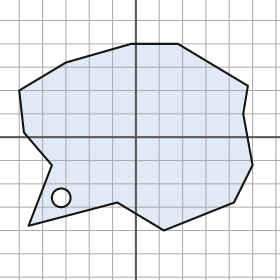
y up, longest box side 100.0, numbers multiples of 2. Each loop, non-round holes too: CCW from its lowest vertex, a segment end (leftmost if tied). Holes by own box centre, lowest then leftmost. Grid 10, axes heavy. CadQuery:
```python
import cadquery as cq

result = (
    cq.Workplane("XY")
    .moveTo(12.0, -40.0)
    .lineTo(42.0, -28.0)
    .lineTo(50.0, -12.0)
    .lineTo(46.0, 10.0)
    .lineTo(48.0, 22.0)
    .lineTo(18.0, 40.0)
    .lineTo(-2.0, 40.0)
    .lineTo(-30.0, 32.0)
    .lineTo(-50.0, 20.0)
    .lineTo(-48.0, 2.0)
    .lineTo(-36.0, -12.0)
    .lineTo(-46.0, -38.0)
    .lineTo(-8.0, -28.0)
    .close()
    .moveTo(-32.0, -26.0)
    .circle(4.0)
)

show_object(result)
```